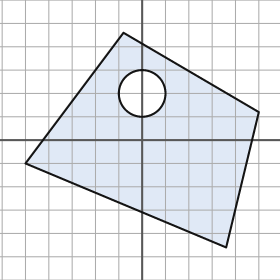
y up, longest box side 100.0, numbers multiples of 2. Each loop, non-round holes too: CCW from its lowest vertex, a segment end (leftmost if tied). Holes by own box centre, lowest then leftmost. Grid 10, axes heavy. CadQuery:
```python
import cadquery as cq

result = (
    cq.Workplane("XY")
    .moveTo(36.0, -46.0)
    .lineTo(50.0, 12.0)
    .lineTo(-8.0, 46.0)
    .lineTo(-50.0, -10.0)
    .close()
    .moveTo(0.0, 20.0)
    .circle(10.0)
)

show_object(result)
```